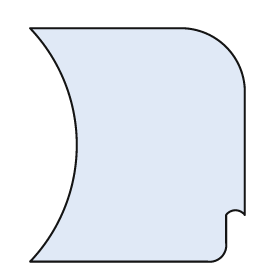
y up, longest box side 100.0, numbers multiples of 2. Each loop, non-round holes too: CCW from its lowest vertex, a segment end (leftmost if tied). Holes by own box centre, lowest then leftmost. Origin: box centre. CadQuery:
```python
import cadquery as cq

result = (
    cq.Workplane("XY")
    .moveTo(-46.0, -50.0)
    .lineTo(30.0, -50.0)
    .threePointArc((36.0, -48.0), (38.0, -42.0))
    .lineTo(38.0, -30.0)
    .threePointArc((42.0, -28.0), (46.0, -30.0))
    .lineTo(46.0, 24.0)
    .threePointArc((38.0, 42.0), (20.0, 50.0))
    .lineTo(-46.0, 50.0)
    .threePointArc((-26.0, 0.0), (-46.0, -50.0))
    .close()
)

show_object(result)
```